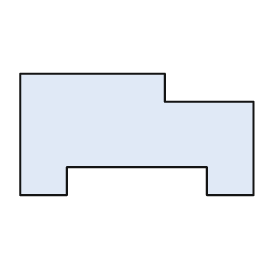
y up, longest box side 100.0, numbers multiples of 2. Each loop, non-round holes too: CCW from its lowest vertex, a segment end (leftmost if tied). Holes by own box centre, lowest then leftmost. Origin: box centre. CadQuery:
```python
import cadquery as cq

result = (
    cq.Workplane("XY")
    .moveTo(-50.0, -26.0)
    .lineTo(-30.0, -26.0)
    .lineTo(-30.0, -14.0)
    .lineTo(30.0, -14.0)
    .lineTo(30.0, -26.0)
    .lineTo(50.0, -26.0)
    .lineTo(50.0, 14.0)
    .lineTo(12.0, 14.0)
    .lineTo(12.0, 26.0)
    .lineTo(-50.0, 26.0)
    .close()
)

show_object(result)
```